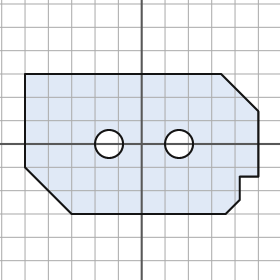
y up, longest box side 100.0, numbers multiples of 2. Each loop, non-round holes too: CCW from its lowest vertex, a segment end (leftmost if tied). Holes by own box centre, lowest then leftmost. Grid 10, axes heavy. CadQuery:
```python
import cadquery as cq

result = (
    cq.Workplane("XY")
    .moveTo(-30.0, -30.0)
    .lineTo(36.0, -30.0)
    .lineTo(42.0, -24.0)
    .lineTo(42.0, -14.0)
    .lineTo(50.0, -14.0)
    .lineTo(50.0, 14.0)
    .lineTo(34.0, 30.0)
    .lineTo(-50.0, 30.0)
    .lineTo(-50.0, -10.0)
    .close()
    .moveTo(-14.0, 0.0)
    .circle(6.0)
    .moveTo(16.0, 0.0)
    .circle(6.0)
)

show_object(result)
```